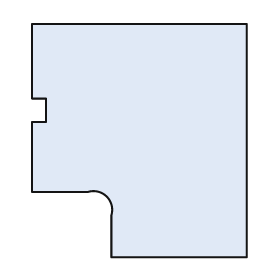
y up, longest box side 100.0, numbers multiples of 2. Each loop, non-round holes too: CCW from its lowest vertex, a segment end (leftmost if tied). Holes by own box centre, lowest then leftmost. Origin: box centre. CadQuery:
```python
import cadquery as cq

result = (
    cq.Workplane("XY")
    .moveTo(-12.0, -50.0)
    .lineTo(46.0, -50.0)
    .lineTo(46.0, 50.0)
    .lineTo(-46.0, 50.0)
    .lineTo(-46.0, 18.0)
    .lineTo(-40.0, 18.0)
    .lineTo(-40.0, 8.0)
    .lineTo(-46.0, 8.0)
    .lineTo(-46.0, -22.0)
    .lineTo(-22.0, -22.0)
    .threePointArc((-14.0, -24.0), (-12.0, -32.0))
    .close()
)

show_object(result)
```